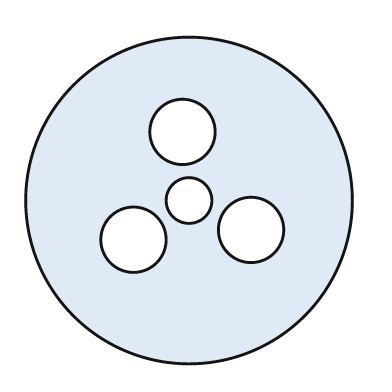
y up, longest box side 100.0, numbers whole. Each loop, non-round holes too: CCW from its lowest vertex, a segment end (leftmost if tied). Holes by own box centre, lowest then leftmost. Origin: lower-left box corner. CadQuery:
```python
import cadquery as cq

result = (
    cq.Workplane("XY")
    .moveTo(50.0, 50.0)
    .circle(50.0)
    .moveTo(33.0, 38.0)
    .circle(10.0)
    .moveTo(69.0, 41.0)
    .circle(10.0)
    .moveTo(50.0, 50.0)
    .circle(7.0)
    .moveTo(48.0, 71.0)
    .circle(10.0)
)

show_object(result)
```